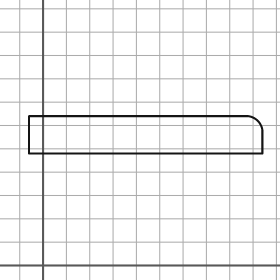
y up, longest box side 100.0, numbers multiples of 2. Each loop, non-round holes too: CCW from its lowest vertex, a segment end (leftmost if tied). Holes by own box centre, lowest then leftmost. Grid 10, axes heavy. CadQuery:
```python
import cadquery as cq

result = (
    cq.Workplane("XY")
    .moveTo(-6.0, 48.0)
    .lineTo(94.0, 48.0)
    .lineTo(94.0, 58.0)
    .threePointArc((92.0, 62.0), (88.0, 64.0))
    .lineTo(-6.0, 64.0)
    .close()
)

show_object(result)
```